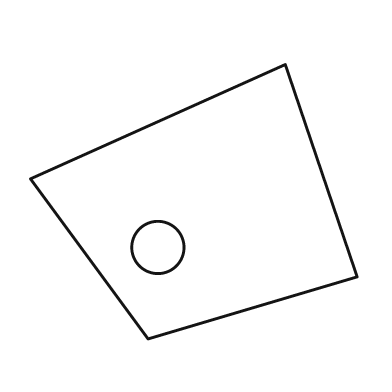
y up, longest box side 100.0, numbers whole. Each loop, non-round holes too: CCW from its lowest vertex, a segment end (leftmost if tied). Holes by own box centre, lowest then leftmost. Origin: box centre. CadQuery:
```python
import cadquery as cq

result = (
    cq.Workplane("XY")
    .moveTo(-14.0, -42.0)
    .lineTo(50.0, -23.0)
    .lineTo(28.0, 42.0)
    .lineTo(-50.0, 7.0)
    .close()
    .moveTo(-11.0, -14.0)
    .circle(8.0)
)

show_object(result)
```